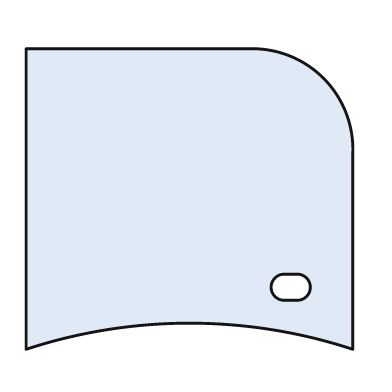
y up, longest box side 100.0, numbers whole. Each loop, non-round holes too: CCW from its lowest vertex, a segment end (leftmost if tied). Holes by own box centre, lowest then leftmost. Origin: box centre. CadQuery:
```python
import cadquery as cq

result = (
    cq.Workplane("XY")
    .moveTo(-50.0, -46.0)
    .threePointArc((0.0, -38.0), (50.0, -46.0))
    .lineTo(50.0, 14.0)
    .threePointArc((41.0, 37.0), (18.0, 46.0))
    .lineTo(-50.0, 46.0)
    .close()
    .moveTo(29.0, -31.0)
    .lineTo(33.0, -31.0)
    .threePointArc((37.0, -27.0), (33.0, -23.0))
    .lineTo(29.0, -23.0)
    .threePointArc((25.0, -27.0), (29.0, -31.0))
    .close()
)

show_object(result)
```